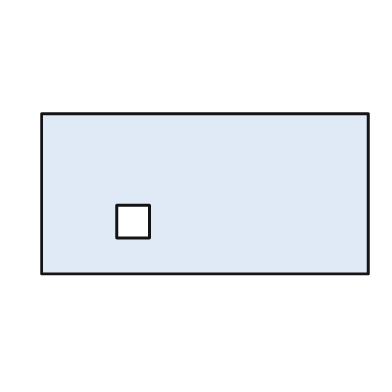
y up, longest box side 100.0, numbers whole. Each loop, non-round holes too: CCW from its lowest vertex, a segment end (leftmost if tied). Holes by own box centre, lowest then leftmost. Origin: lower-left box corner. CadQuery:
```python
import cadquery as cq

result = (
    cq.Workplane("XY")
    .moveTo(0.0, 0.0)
    .lineTo(100.0, 0.0)
    .lineTo(100.0, 49.0)
    .lineTo(0.0, 49.0)
    .close()
    .moveTo(23.0, 11.0)
    .lineTo(33.0, 11.0)
    .lineTo(33.0, 21.0)
    .lineTo(23.0, 21.0)
    .close()
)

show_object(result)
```